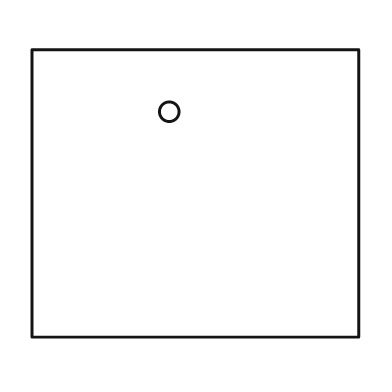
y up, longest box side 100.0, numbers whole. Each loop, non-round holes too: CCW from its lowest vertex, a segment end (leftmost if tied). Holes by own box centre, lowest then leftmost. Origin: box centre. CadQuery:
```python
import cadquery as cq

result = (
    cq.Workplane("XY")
    .moveTo(-50.0, -44.0)
    .lineTo(50.0, -44.0)
    .lineTo(50.0, 44.0)
    .lineTo(-50.0, 44.0)
    .close()
    .moveTo(-8.0, 25.0)
    .circle(3.0)
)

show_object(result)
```